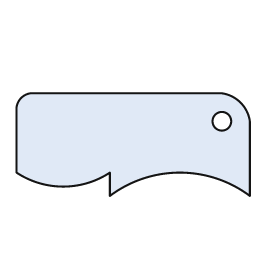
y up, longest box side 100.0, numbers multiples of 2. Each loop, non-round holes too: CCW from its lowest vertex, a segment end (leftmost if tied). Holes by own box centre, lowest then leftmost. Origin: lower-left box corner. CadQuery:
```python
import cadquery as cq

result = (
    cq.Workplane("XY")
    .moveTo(40.0, 0.0)
    .threePointArc((70.0, 10.0), (100.0, 0.0))
    .lineTo(100.0, 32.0)
    .threePointArc((96.0, 40.0), (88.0, 44.0))
    .lineTo(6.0, 44.0)
    .threePointArc((2.0, 42.0), (0.0, 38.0))
    .lineTo(0.0, 10.0)
    .threePointArc((20.0, 4.0), (40.0, 10.0))
    .close()
    .moveTo(88.0, 32.0)
    .circle(4.0)
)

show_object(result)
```